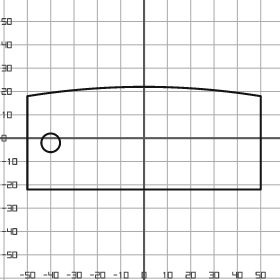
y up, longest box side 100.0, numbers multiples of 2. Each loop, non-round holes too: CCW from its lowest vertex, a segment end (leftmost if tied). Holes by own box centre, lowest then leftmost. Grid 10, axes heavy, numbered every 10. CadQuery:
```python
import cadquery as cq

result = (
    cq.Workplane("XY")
    .moveTo(-50.0, -22.0)
    .lineTo(50.0, -22.0)
    .lineTo(50.0, 18.0)
    .threePointArc((0.0, 22.0), (-50.0, 18.0))
    .close()
    .moveTo(-40.0, -2.0)
    .circle(4.0)
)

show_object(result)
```